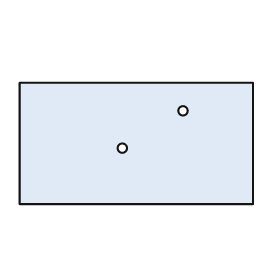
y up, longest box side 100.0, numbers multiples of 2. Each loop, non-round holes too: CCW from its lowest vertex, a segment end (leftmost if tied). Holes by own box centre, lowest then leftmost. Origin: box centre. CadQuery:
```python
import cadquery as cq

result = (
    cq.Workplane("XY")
    .moveTo(-50.0, -26.0)
    .lineTo(50.0, -26.0)
    .lineTo(50.0, 26.0)
    .lineTo(-50.0, 26.0)
    .close()
    .moveTo(-6.0, -2.0)
    .circle(2.0)
    .moveTo(20.0, 14.0)
    .circle(2.0)
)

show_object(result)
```